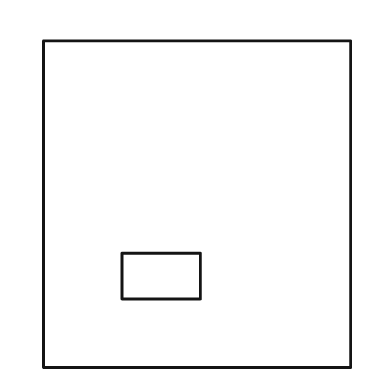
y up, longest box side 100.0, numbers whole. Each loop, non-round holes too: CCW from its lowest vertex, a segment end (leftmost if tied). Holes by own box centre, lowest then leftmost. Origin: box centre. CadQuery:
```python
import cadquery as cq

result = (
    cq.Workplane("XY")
    .moveTo(-47.0, -50.0)
    .lineTo(47.0, -50.0)
    .lineTo(47.0, 50.0)
    .lineTo(-47.0, 50.0)
    .close()
    .moveTo(-23.0, -29.0)
    .lineTo(1.0, -29.0)
    .lineTo(1.0, -15.0)
    .lineTo(-23.0, -15.0)
    .close()
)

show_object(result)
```